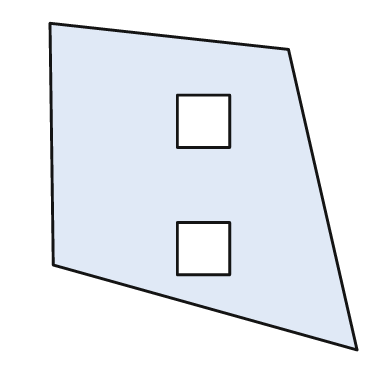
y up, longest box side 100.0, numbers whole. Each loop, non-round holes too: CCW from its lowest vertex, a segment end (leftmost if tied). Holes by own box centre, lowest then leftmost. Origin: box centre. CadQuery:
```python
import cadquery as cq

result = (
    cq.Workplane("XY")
    .moveTo(47.0, -50.0)
    .lineTo(26.0, 42.0)
    .lineTo(-47.0, 50.0)
    .lineTo(-46.0, -24.0)
    .close()
    .moveTo(-8.0, -27.0)
    .lineTo(8.0, -27.0)
    .lineTo(8.0, -11.0)
    .lineTo(-8.0, -11.0)
    .close()
    .moveTo(-8.0, 12.0)
    .lineTo(8.0, 12.0)
    .lineTo(8.0, 28.0)
    .lineTo(-8.0, 28.0)
    .close()
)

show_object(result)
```